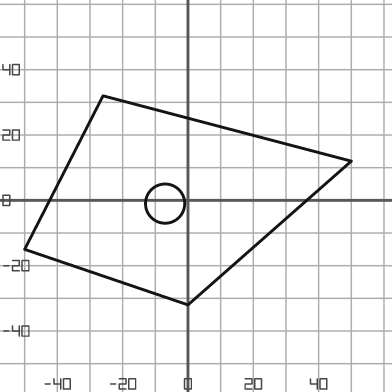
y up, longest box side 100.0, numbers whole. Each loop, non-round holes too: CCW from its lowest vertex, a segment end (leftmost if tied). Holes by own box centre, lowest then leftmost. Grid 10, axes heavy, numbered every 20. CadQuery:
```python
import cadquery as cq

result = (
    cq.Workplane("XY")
    .moveTo(0.0, -32.0)
    .lineTo(50.0, 12.0)
    .lineTo(-26.0, 32.0)
    .lineTo(-50.0, -15.0)
    .close()
    .moveTo(-7.0, -1.0)
    .circle(6.0)
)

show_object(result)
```